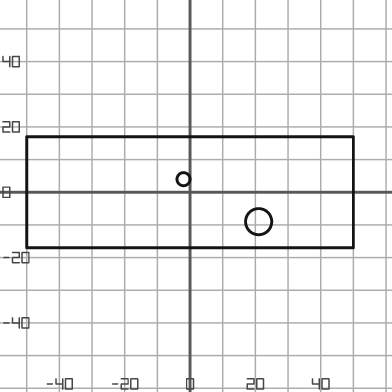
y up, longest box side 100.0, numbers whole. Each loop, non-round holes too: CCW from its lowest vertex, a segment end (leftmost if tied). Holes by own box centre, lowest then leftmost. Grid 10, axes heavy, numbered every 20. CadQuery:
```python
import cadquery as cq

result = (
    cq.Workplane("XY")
    .moveTo(-50.0, -17.0)
    .lineTo(50.0, -17.0)
    .lineTo(50.0, 17.0)
    .lineTo(-50.0, 17.0)
    .close()
    .moveTo(21.0, -9.0)
    .circle(4.0)
    .moveTo(-2.0, 4.0)
    .circle(2.0)
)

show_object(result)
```